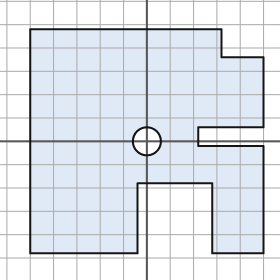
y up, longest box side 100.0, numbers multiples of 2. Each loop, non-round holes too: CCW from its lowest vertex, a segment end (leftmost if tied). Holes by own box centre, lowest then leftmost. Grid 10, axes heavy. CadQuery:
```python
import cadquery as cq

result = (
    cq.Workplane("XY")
    .moveTo(-50.0, -48.0)
    .lineTo(-4.0, -48.0)
    .lineTo(-4.0, -18.0)
    .lineTo(28.0, -18.0)
    .lineTo(28.0, -48.0)
    .lineTo(50.0, -48.0)
    .lineTo(50.0, -2.0)
    .lineTo(22.0, -2.0)
    .lineTo(22.0, 6.0)
    .lineTo(50.0, 6.0)
    .lineTo(50.0, 36.0)
    .lineTo(32.0, 36.0)
    .lineTo(32.0, 48.0)
    .lineTo(-50.0, 48.0)
    .close()
    .moveTo(0.0, 0.0)
    .circle(6.0)
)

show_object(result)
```